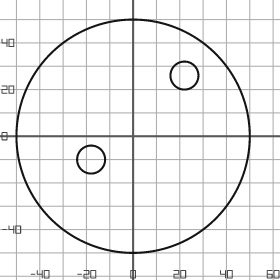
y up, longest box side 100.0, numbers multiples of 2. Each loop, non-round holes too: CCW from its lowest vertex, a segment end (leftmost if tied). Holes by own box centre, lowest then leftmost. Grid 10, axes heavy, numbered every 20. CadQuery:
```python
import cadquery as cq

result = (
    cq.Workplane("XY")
    .moveTo(0.0, 0.0)
    .circle(50.0)
    .moveTo(-18.0, -10.0)
    .circle(6.0)
    .moveTo(22.0, 26.0)
    .circle(6.0)
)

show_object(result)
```